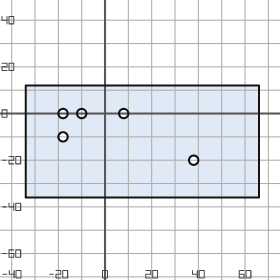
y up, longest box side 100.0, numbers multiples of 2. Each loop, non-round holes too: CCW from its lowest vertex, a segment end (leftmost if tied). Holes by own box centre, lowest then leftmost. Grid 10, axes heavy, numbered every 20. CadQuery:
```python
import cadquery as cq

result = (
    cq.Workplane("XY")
    .moveTo(-34.0, -36.0)
    .lineTo(66.0, -36.0)
    .lineTo(66.0, 12.0)
    .lineTo(-34.0, 12.0)
    .close()
    .moveTo(38.0, -20.0)
    .circle(2.0)
    .moveTo(-18.0, -10.0)
    .circle(2.0)
    .moveTo(-18.0, 0.0)
    .circle(2.0)
    .moveTo(-10.0, 0.0)
    .circle(2.0)
    .moveTo(8.0, 0.0)
    .circle(2.0)
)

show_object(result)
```